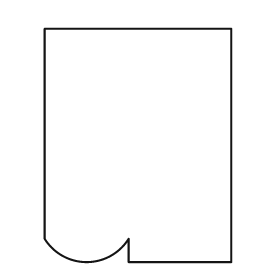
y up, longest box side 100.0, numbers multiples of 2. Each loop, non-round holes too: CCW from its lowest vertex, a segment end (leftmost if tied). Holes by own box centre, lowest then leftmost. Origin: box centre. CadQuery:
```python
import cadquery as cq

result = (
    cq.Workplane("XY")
    .moveTo(-4.0, -50.0)
    .lineTo(40.0, -50.0)
    .lineTo(40.0, 50.0)
    .lineTo(-40.0, 50.0)
    .lineTo(-40.0, -40.0)
    .threePointArc((-22.0, -50.0), (-4.0, -40.0))
    .close()
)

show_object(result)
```